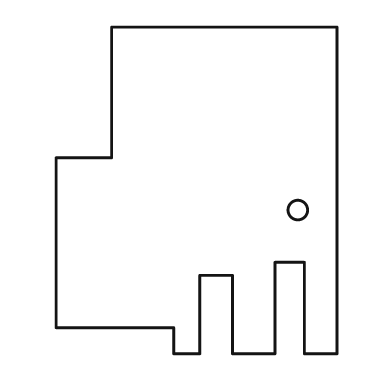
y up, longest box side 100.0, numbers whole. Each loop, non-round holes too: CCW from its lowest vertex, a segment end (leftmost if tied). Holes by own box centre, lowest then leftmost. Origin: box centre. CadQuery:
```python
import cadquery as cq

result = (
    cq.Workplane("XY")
    .moveTo(-7.0, -50.0)
    .lineTo(1.0, -50.0)
    .lineTo(1.0, -26.0)
    .lineTo(11.0, -26.0)
    .lineTo(11.0, -50.0)
    .lineTo(24.0, -50.0)
    .lineTo(24.0, -22.0)
    .lineTo(33.0, -22.0)
    .lineTo(33.0, -50.0)
    .lineTo(43.0, -50.0)
    .lineTo(43.0, 50.0)
    .lineTo(-26.0, 50.0)
    .lineTo(-26.0, 10.0)
    .lineTo(-43.0, 10.0)
    .lineTo(-43.0, -42.0)
    .lineTo(-7.0, -42.0)
    .close()
    .moveTo(31.0, -6.0)
    .circle(3.0)
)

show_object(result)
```